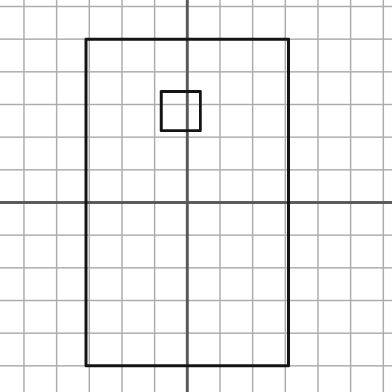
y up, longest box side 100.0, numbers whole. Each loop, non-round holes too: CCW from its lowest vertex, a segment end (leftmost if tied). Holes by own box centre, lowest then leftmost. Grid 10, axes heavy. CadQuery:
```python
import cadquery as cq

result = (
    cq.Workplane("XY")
    .moveTo(-31.0, -50.0)
    .lineTo(31.0, -50.0)
    .lineTo(31.0, 50.0)
    .lineTo(-31.0, 50.0)
    .close()
    .moveTo(-8.0, 22.0)
    .lineTo(4.0, 22.0)
    .lineTo(4.0, 34.0)
    .lineTo(-8.0, 34.0)
    .close()
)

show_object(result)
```